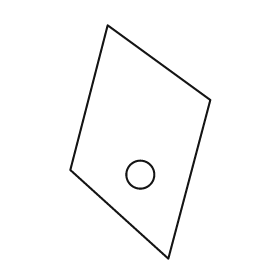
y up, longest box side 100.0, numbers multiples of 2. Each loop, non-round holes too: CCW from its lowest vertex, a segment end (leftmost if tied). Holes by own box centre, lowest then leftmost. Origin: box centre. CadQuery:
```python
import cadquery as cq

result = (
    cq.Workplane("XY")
    .moveTo(12.0, -50.0)
    .lineTo(30.0, 18.0)
    .lineTo(-14.0, 50.0)
    .lineTo(-30.0, -12.0)
    .close()
    .moveTo(0.0, -14.0)
    .circle(6.0)
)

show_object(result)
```